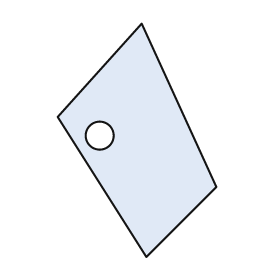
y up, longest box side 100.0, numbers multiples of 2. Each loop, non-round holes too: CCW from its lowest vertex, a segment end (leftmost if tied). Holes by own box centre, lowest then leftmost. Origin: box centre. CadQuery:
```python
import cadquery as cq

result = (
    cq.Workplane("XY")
    .moveTo(4.0, -50.0)
    .lineTo(34.0, -20.0)
    .lineTo(2.0, 50.0)
    .lineTo(-34.0, 10.0)
    .close()
    .moveTo(-16.0, 2.0)
    .circle(6.0)
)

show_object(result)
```